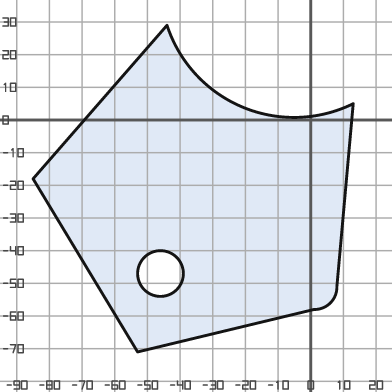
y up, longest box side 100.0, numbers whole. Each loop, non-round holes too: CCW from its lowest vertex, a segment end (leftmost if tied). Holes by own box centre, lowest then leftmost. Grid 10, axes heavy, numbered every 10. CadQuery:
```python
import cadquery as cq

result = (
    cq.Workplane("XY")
    .moveTo(-53.0, -71.0)
    .lineTo(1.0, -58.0)
    .threePointArc((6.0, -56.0), (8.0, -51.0))
    .lineTo(13.0, 5.0)
    .threePointArc((-21.0, 4.0), (-44.0, 29.0))
    .lineTo(-85.0, -18.0)
    .close()
    .moveTo(-46.0, -47.0)
    .circle(7.0)
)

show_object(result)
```